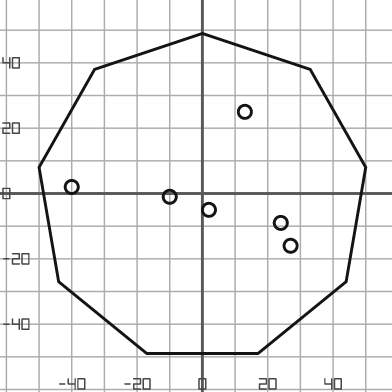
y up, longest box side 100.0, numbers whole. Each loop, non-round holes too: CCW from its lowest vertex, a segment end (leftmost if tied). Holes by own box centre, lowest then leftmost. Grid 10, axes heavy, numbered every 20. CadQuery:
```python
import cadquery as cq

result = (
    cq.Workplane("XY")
    .moveTo(-17.0, -49.0)
    .lineTo(17.0, -49.0)
    .lineTo(44.0, -27.0)
    .lineTo(50.0, 8.0)
    .lineTo(33.0, 38.0)
    .lineTo(0.0, 49.0)
    .lineTo(-33.0, 38.0)
    .lineTo(-50.0, 8.0)
    .lineTo(-44.0, -27.0)
    .close()
    .moveTo(27.0, -16.0)
    .circle(2.0)
    .moveTo(24.0, -9.0)
    .circle(2.0)
    .moveTo(2.0, -5.0)
    .circle(2.0)
    .moveTo(-10.0, -1.0)
    .circle(2.0)
    .moveTo(-40.0, 2.0)
    .circle(2.0)
    .moveTo(13.0, 25.0)
    .circle(2.0)
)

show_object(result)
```